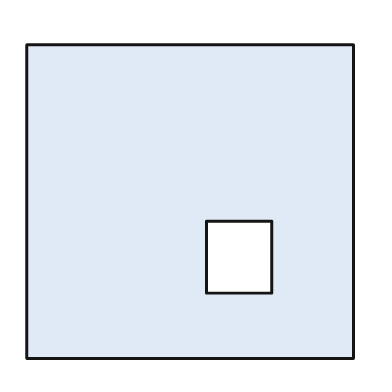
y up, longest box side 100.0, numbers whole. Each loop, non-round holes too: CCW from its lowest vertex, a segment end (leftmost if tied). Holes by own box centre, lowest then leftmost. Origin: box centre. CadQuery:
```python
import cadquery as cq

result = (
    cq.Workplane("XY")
    .moveTo(-50.0, -48.0)
    .lineTo(50.0, -48.0)
    .lineTo(50.0, 48.0)
    .lineTo(-50.0, 48.0)
    .close()
    .moveTo(5.0, -28.0)
    .lineTo(25.0, -28.0)
    .lineTo(25.0, -6.0)
    .lineTo(5.0, -6.0)
    .close()
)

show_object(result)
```